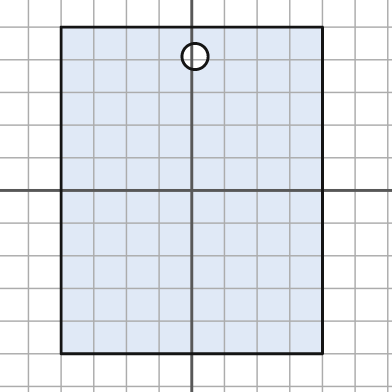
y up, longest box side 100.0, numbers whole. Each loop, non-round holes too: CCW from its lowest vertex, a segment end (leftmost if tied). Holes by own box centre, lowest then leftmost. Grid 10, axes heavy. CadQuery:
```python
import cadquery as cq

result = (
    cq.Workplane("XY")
    .moveTo(-40.0, -50.0)
    .lineTo(40.0, -50.0)
    .lineTo(40.0, 50.0)
    .lineTo(-40.0, 50.0)
    .close()
    .moveTo(1.0, 41.0)
    .circle(4.0)
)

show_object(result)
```